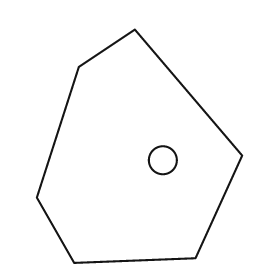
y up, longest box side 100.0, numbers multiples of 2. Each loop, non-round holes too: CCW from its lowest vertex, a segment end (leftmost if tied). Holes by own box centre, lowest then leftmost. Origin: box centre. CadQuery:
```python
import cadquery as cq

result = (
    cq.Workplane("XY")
    .moveTo(-28.0, -50.0)
    .lineTo(24.0, -48.0)
    .lineTo(44.0, -4.0)
    .lineTo(-2.0, 50.0)
    .lineTo(-26.0, 34.0)
    .lineTo(-44.0, -22.0)
    .close()
    .moveTo(10.0, -6.0)
    .circle(6.0)
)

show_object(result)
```